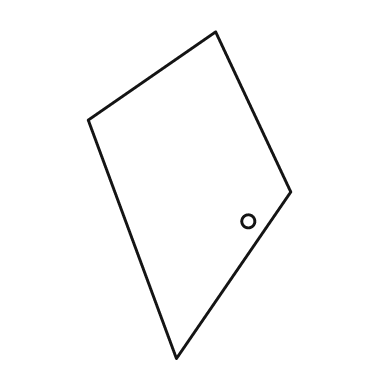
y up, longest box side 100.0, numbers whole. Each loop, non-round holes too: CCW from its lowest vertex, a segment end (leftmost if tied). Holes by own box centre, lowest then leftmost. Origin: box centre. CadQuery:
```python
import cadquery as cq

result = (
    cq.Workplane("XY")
    .moveTo(-4.0, -50.0)
    .lineTo(31.0, 1.0)
    .lineTo(8.0, 50.0)
    .lineTo(-31.0, 23.0)
    .close()
    .moveTo(18.0, -8.0)
    .circle(2.0)
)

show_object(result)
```